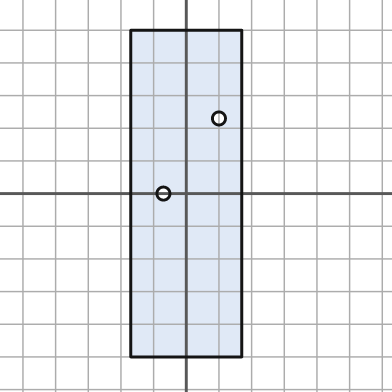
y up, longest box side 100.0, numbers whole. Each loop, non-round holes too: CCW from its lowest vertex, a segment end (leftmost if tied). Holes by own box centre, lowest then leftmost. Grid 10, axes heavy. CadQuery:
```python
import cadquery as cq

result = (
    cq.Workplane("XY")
    .moveTo(-17.0, -50.0)
    .lineTo(17.0, -50.0)
    .lineTo(17.0, 50.0)
    .lineTo(-17.0, 50.0)
    .close()
    .moveTo(-7.0, 0.0)
    .circle(2.0)
    .moveTo(10.0, 23.0)
    .circle(2.0)
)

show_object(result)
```